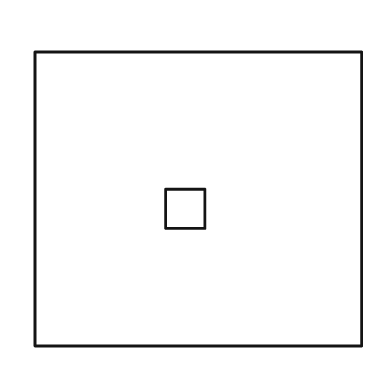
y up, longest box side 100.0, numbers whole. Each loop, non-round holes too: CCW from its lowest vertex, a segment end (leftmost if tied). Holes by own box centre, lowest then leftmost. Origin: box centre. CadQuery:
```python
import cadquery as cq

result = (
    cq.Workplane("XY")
    .moveTo(-50.0, -45.0)
    .lineTo(50.0, -45.0)
    .lineTo(50.0, 45.0)
    .lineTo(-50.0, 45.0)
    .close()
    .moveTo(-10.0, -9.0)
    .lineTo(2.0, -9.0)
    .lineTo(2.0, 3.0)
    .lineTo(-10.0, 3.0)
    .close()
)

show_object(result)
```